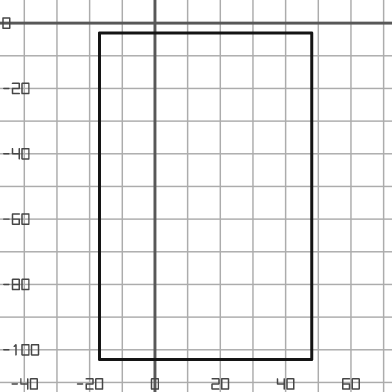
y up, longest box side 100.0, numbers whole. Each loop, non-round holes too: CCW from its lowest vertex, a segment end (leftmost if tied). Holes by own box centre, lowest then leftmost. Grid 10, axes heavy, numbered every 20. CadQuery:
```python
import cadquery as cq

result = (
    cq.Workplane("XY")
    .moveTo(-17.0, -103.0)
    .lineTo(48.0, -103.0)
    .lineTo(48.0, -3.0)
    .lineTo(-17.0, -3.0)
    .close()
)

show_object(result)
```